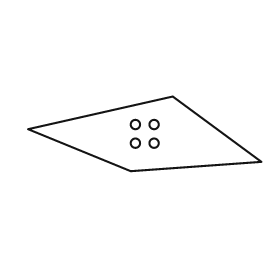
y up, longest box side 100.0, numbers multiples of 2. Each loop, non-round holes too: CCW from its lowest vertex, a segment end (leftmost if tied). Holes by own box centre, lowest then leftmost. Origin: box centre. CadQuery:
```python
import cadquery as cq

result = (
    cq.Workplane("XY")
    .moveTo(-6.0, -16.0)
    .lineTo(50.0, -12.0)
    .lineTo(12.0, 16.0)
    .lineTo(-50.0, 2.0)
    .close()
    .moveTo(-4.0, -4.0)
    .circle(2.0)
    .moveTo(4.0, -4.0)
    .circle(2.0)
    .moveTo(-4.0, 4.0)
    .circle(2.0)
    .moveTo(4.0, 4.0)
    .circle(2.0)
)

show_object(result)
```